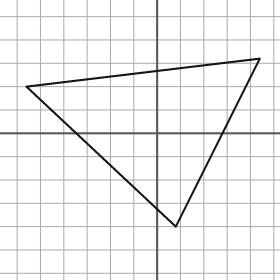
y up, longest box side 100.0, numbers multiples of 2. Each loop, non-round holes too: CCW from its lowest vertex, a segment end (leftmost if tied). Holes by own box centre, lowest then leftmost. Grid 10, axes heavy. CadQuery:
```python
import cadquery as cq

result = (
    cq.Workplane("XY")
    .moveTo(8.0, -40.0)
    .lineTo(44.0, 32.0)
    .lineTo(-56.0, 20.0)
    .close()
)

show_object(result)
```